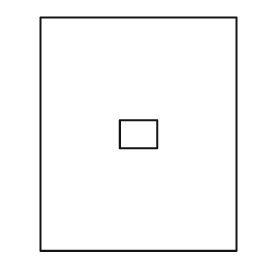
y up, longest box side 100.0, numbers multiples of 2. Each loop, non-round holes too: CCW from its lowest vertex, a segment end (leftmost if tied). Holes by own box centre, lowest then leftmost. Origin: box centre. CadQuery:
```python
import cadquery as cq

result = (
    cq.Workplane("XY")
    .moveTo(-42.0, -50.0)
    .lineTo(42.0, -50.0)
    .lineTo(42.0, 50.0)
    .lineTo(-42.0, 50.0)
    .close()
    .moveTo(-8.0, -6.0)
    .lineTo(8.0, -6.0)
    .lineTo(8.0, 6.0)
    .lineTo(-8.0, 6.0)
    .close()
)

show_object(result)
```